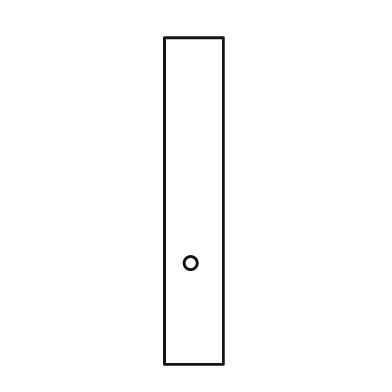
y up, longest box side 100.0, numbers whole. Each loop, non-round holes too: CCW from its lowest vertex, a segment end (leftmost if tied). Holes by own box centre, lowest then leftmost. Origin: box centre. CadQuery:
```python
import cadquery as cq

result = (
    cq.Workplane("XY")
    .moveTo(-9.0, -50.0)
    .lineTo(9.0, -50.0)
    .lineTo(9.0, 50.0)
    .lineTo(-9.0, 50.0)
    .close()
    .moveTo(-1.0, -19.0)
    .circle(2.0)
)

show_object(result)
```